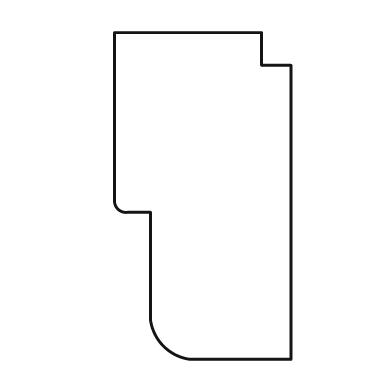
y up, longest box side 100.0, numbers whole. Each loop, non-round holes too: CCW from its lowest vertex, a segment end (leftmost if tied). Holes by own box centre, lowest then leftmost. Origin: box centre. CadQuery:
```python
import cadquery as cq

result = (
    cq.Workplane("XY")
    .moveTo(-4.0, -50.0)
    .lineTo(27.0, -50.0)
    .lineTo(27.0, 40.0)
    .lineTo(18.0, 40.0)
    .lineTo(18.0, 50.0)
    .lineTo(-27.0, 50.0)
    .lineTo(-27.0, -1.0)
    .threePointArc((-26.0, -4.0), (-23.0, -5.0))
    .lineTo(-16.0, -5.0)
    .lineTo(-16.0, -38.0)
    .threePointArc((-12.0, -46.0), (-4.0, -50.0))
    .close()
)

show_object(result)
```